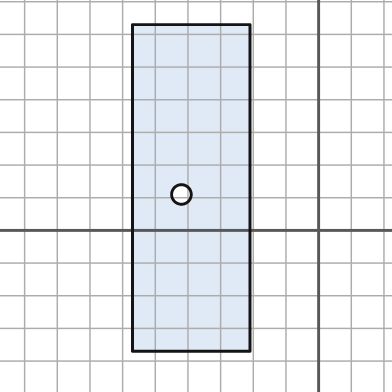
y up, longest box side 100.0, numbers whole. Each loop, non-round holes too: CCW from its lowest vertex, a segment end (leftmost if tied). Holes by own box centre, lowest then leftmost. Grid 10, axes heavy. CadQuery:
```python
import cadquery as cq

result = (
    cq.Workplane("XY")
    .moveTo(-57.0, -37.0)
    .lineTo(-21.0, -37.0)
    .lineTo(-21.0, 63.0)
    .lineTo(-57.0, 63.0)
    .close()
    .moveTo(-42.0, 11.0)
    .circle(3.0)
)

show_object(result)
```